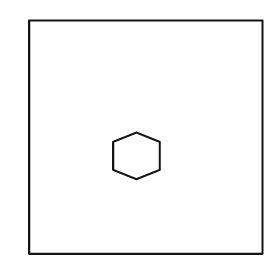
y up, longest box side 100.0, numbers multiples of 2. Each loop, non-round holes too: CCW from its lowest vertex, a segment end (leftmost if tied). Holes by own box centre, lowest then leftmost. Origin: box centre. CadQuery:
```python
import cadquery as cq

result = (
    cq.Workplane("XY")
    .moveTo(-50.0, -50.0)
    .lineTo(50.0, -50.0)
    .lineTo(50.0, 50.0)
    .lineTo(-50.0, 50.0)
    .close()
    .moveTo(-4.0, -18.0)
    .lineTo(6.0, -14.0)
    .lineTo(6.0, -2.0)
    .lineTo(-4.0, 2.0)
    .lineTo(-14.0, -2.0)
    .lineTo(-14.0, -14.0)
    .close()
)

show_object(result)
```